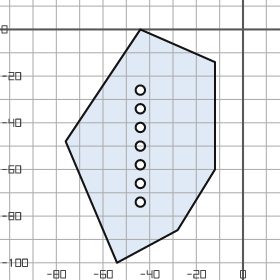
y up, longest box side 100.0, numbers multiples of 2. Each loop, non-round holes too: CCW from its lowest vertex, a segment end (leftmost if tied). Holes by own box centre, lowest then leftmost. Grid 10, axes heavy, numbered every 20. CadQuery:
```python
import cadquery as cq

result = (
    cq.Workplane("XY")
    .moveTo(-54.0, -100.0)
    .lineTo(-28.0, -86.0)
    .lineTo(-12.0, -60.0)
    .lineTo(-12.0, -14.0)
    .lineTo(-44.0, 0.0)
    .lineTo(-76.0, -48.0)
    .close()
    .moveTo(-44.0, -74.0)
    .circle(2.0)
    .moveTo(-44.0, -66.0)
    .circle(2.0)
    .moveTo(-44.0, -58.0)
    .circle(2.0)
    .moveTo(-44.0, -50.0)
    .circle(2.0)
    .moveTo(-44.0, -42.0)
    .circle(2.0)
    .moveTo(-44.0, -34.0)
    .circle(2.0)
    .moveTo(-44.0, -26.0)
    .circle(2.0)
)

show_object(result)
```